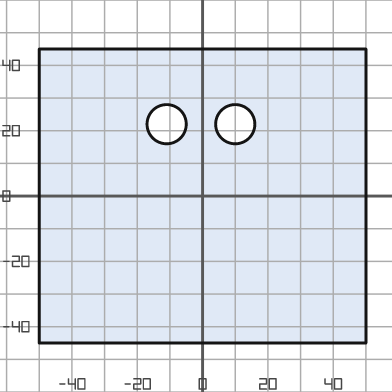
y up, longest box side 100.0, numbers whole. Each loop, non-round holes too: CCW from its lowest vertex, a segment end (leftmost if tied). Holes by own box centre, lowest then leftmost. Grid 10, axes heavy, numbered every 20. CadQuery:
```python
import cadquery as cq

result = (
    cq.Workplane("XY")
    .moveTo(-50.0, -45.0)
    .lineTo(50.0, -45.0)
    .lineTo(50.0, 45.0)
    .lineTo(-50.0, 45.0)
    .close()
    .moveTo(-11.0, 22.0)
    .circle(6.0)
    .moveTo(10.0, 22.0)
    .circle(6.0)
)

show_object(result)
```